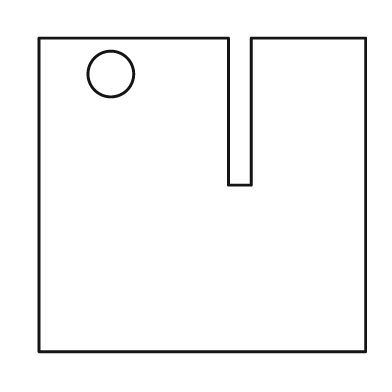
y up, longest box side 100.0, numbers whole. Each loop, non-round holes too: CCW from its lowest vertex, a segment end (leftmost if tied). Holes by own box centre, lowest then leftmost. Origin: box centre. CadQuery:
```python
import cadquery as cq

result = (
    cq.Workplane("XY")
    .moveTo(-50.0, -48.0)
    .lineTo(50.0, -48.0)
    .lineTo(50.0, 48.0)
    .lineTo(15.0, 48.0)
    .lineTo(15.0, 3.0)
    .lineTo(8.0, 3.0)
    .lineTo(8.0, 48.0)
    .lineTo(-50.0, 48.0)
    .close()
    .moveTo(-28.0, 37.0)
    .circle(7.0)
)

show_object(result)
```